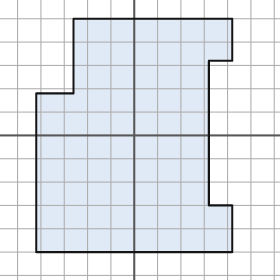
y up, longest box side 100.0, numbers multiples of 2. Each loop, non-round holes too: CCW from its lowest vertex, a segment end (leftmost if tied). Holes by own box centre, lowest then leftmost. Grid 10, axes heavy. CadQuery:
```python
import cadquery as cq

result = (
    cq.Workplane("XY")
    .moveTo(-42.0, -50.0)
    .lineTo(42.0, -50.0)
    .lineTo(42.0, -30.0)
    .lineTo(32.0, -30.0)
    .lineTo(32.0, 32.0)
    .lineTo(42.0, 32.0)
    .lineTo(42.0, 50.0)
    .lineTo(-26.0, 50.0)
    .lineTo(-26.0, 18.0)
    .lineTo(-42.0, 18.0)
    .close()
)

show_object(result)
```